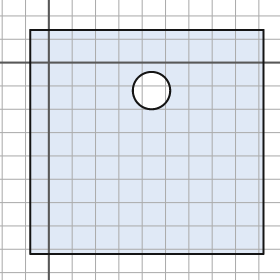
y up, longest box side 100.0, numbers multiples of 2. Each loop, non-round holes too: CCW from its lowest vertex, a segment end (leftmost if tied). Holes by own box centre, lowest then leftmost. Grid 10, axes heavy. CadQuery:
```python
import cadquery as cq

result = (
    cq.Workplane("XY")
    .moveTo(-8.0, -82.0)
    .lineTo(92.0, -82.0)
    .lineTo(92.0, 14.0)
    .lineTo(-8.0, 14.0)
    .close()
    .moveTo(44.0, -12.0)
    .circle(8.0)
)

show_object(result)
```